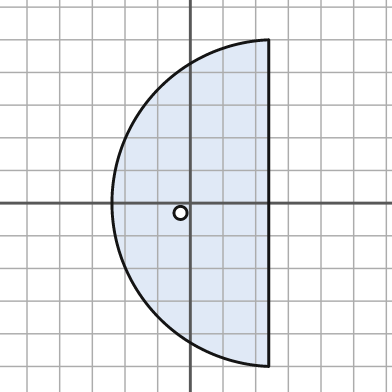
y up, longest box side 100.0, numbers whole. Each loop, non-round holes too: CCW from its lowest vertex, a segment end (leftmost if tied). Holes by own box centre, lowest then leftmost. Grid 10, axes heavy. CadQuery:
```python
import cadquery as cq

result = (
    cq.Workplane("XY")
    .moveTo(24.0, -50.0)
    .lineTo(24.0, 50.0)
    .threePointArc((-24.0, 0.0), (24.0, -50.0))
    .close()
    .moveTo(-3.0, -3.0)
    .circle(2.0)
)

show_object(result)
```